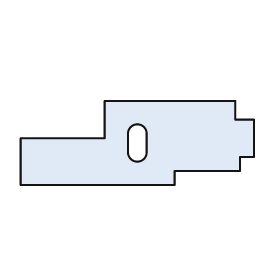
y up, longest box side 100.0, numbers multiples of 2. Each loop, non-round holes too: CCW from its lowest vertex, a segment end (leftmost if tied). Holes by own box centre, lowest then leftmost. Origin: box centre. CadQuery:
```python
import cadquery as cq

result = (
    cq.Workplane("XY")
    .moveTo(-50.0, -18.0)
    .lineTo(16.0, -18.0)
    .lineTo(16.0, -12.0)
    .lineTo(44.0, -12.0)
    .lineTo(44.0, -6.0)
    .lineTo(50.0, -6.0)
    .lineTo(50.0, 10.0)
    .lineTo(42.0, 10.0)
    .lineTo(42.0, 18.0)
    .lineTo(-14.0, 18.0)
    .lineTo(-14.0, 2.0)
    .lineTo(-50.0, 2.0)
    .close()
    .moveTo(-4.0, -4.0)
    .threePointArc((0.0, -8.0), (4.0, -4.0))
    .lineTo(4.0, 4.0)
    .threePointArc((0.0, 8.0), (-4.0, 4.0))
    .close()
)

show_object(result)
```